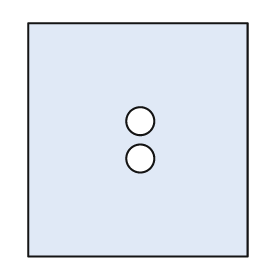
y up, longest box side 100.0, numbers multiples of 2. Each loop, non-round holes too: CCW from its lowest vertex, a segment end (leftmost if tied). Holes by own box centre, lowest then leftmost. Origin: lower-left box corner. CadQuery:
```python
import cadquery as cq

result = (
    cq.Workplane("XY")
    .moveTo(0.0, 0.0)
    .lineTo(94.0, 0.0)
    .lineTo(94.0, 100.0)
    .lineTo(0.0, 100.0)
    .close()
    .moveTo(48.0, 42.0)
    .circle(6.0)
    .moveTo(48.0, 58.0)
    .circle(6.0)
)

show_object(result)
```